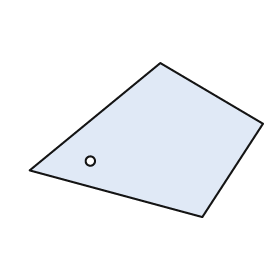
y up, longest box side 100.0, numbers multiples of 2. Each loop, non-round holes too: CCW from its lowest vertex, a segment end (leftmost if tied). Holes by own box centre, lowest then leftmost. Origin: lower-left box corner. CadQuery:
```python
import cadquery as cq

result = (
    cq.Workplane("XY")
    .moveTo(74.0, 0.0)
    .lineTo(100.0, 40.0)
    .lineTo(56.0, 66.0)
    .lineTo(0.0, 20.0)
    .close()
    .moveTo(26.0, 24.0)
    .circle(2.0)
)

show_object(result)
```